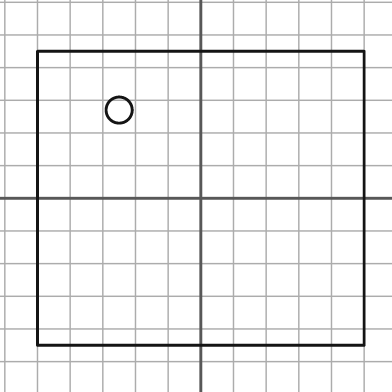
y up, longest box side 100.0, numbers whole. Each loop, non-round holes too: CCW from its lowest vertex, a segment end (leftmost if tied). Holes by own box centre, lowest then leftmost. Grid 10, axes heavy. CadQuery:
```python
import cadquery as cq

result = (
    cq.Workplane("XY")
    .moveTo(-50.0, -45.0)
    .lineTo(50.0, -45.0)
    .lineTo(50.0, 45.0)
    .lineTo(-50.0, 45.0)
    .close()
    .moveTo(-25.0, 27.0)
    .circle(4.0)
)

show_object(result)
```